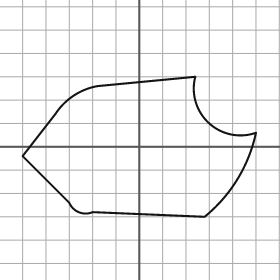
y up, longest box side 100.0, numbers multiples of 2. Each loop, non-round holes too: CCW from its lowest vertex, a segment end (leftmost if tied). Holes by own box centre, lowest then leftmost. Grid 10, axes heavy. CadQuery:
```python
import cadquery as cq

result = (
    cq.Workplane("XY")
    .moveTo(28.0, -30.0)
    .threePointArc((42.0, -14.0), (50.0, 6.0))
    .threePointArc((30.0, 10.0), (24.0, 30.0))
    .lineTo(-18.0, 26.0)
    .threePointArc((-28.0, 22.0), (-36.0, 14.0))
    .lineTo(-50.0, -4.0)
    .lineTo(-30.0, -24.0)
    .threePointArc((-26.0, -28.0), (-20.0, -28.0))
    .close()
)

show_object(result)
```